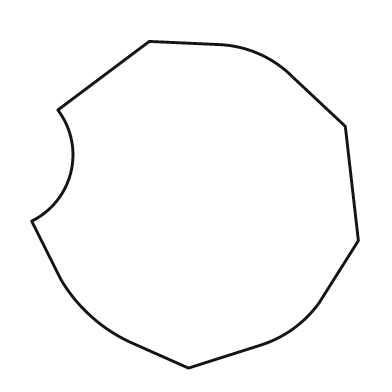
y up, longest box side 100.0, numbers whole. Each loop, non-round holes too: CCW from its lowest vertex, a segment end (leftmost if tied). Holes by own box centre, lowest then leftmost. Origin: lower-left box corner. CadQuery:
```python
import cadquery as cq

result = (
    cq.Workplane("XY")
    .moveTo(48.0, 0.0)
    .lineTo(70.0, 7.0)
    .threePointArc((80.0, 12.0), (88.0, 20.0))
    .lineTo(100.0, 39.0)
    .lineTo(96.0, 74.0)
    .lineTo(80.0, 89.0)
    .threePointArc((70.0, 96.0), (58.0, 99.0))
    .lineTo(36.0, 100.0)
    .lineTo(8.0, 79.0)
    .threePointArc((12.0, 60.0), (0.0, 45.0))
    .lineTo(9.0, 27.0)
    .threePointArc((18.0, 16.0), (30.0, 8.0))
    .close()
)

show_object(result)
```